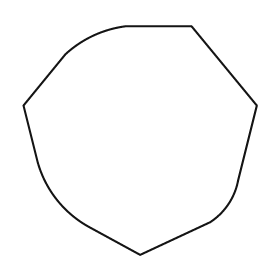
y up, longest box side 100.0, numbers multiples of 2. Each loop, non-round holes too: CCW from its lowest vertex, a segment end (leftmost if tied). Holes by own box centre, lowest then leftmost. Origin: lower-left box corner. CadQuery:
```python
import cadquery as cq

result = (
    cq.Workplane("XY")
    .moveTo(50.0, 0.0)
    .lineTo(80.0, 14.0)
    .threePointArc((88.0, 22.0), (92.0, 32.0))
    .lineTo(100.0, 64.0)
    .lineTo(72.0, 98.0)
    .lineTo(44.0, 98.0)
    .threePointArc((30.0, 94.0), (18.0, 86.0))
    .lineTo(0.0, 64.0)
    .lineTo(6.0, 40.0)
    .threePointArc((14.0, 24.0), (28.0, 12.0))
    .close()
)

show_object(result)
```